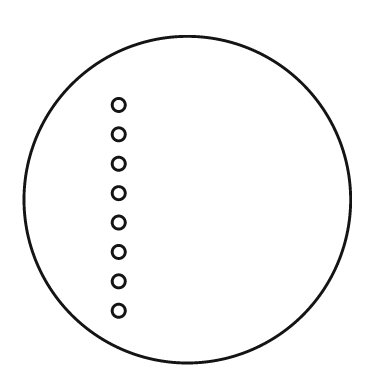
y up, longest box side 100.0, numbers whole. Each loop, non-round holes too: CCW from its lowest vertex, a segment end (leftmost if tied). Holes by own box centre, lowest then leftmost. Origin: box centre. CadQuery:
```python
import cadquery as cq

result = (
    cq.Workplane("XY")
    .moveTo(0.0, 0.0)
    .circle(50.0)
    .moveTo(-21.0, -34.0)
    .circle(2.0)
    .moveTo(-21.0, -25.0)
    .circle(2.0)
    .moveTo(-21.0, -16.0)
    .circle(2.0)
    .moveTo(-21.0, -7.0)
    .circle(2.0)
    .moveTo(-21.0, 2.0)
    .circle(2.0)
    .moveTo(-21.0, 11.0)
    .circle(2.0)
    .moveTo(-21.0, 20.0)
    .circle(2.0)
    .moveTo(-21.0, 29.0)
    .circle(2.0)
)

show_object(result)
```